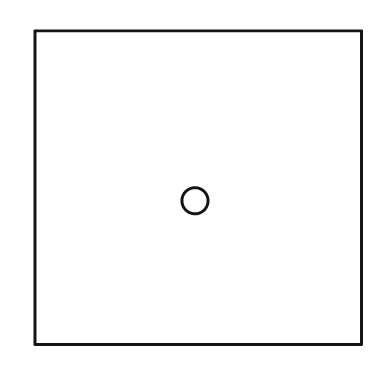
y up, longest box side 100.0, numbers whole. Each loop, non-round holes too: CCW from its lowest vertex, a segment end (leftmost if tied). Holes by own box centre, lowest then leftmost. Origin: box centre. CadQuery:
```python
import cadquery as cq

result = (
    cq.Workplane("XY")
    .moveTo(-50.0, -48.0)
    .lineTo(50.0, -48.0)
    .lineTo(50.0, 48.0)
    .lineTo(-50.0, 48.0)
    .close()
    .moveTo(-1.0, -4.0)
    .circle(4.0)
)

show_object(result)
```